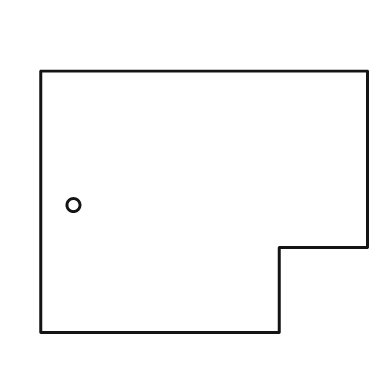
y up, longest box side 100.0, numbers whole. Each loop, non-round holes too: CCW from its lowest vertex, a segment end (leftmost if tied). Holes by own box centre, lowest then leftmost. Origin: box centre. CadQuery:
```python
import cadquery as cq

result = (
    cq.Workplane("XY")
    .moveTo(-50.0, -40.0)
    .lineTo(23.0, -40.0)
    .lineTo(23.0, -14.0)
    .lineTo(50.0, -14.0)
    .lineTo(50.0, 40.0)
    .lineTo(-50.0, 40.0)
    .close()
    .moveTo(-40.0, -1.0)
    .circle(2.0)
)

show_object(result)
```